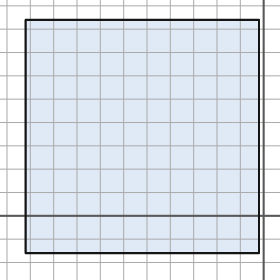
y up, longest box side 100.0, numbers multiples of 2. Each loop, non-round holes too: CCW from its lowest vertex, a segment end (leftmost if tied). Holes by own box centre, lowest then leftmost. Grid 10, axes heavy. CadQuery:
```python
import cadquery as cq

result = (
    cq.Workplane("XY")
    .moveTo(-102.0, -16.0)
    .lineTo(-2.0, -16.0)
    .lineTo(-2.0, 84.0)
    .lineTo(-102.0, 84.0)
    .close()
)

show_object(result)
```